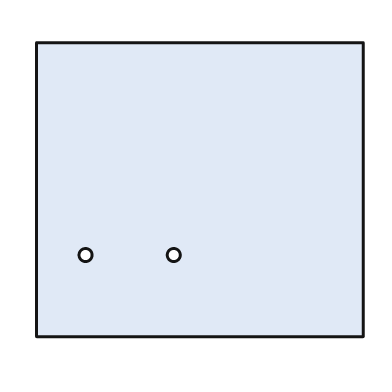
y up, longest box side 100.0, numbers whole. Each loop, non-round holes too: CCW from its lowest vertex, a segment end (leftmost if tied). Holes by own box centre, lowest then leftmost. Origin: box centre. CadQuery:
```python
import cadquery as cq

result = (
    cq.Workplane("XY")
    .moveTo(-50.0, -45.0)
    .lineTo(50.0, -45.0)
    .lineTo(50.0, 45.0)
    .lineTo(-50.0, 45.0)
    .close()
    .moveTo(-35.0, -20.0)
    .circle(2.0)
    .moveTo(-8.0, -20.0)
    .circle(2.0)
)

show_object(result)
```